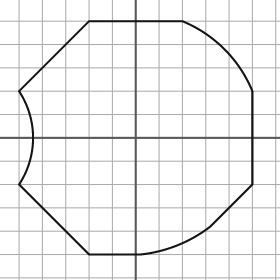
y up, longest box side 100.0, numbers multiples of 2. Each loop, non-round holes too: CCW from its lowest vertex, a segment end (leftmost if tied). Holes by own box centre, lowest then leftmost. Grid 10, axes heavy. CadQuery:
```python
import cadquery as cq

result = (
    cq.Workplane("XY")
    .moveTo(-20.0, -50.0)
    .lineTo(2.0, -50.0)
    .threePointArc((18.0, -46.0), (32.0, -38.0))
    .lineTo(50.0, -20.0)
    .lineTo(50.0, 20.0)
    .threePointArc((38.0, 38.0), (20.0, 50.0))
    .lineTo(-20.0, 50.0)
    .lineTo(-50.0, 20.0)
    .threePointArc((-44.0, 0.0), (-50.0, -20.0))
    .close()
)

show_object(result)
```